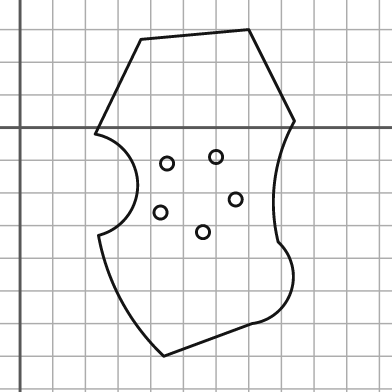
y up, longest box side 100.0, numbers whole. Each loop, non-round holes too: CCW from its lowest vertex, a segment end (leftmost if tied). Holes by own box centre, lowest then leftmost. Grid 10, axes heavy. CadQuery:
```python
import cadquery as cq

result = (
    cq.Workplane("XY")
    .moveTo(44.0, -70.0)
    .lineTo(71.0, -60.0)
    .threePointArc((83.0, -50.0), (79.0, -35.0))
    .threePointArc((78.0, -16.0), (84.0, 2.0))
    .lineTo(70.0, 30.0)
    .lineTo(37.0, 27.0)
    .lineTo(23.0, -2.0)
    .threePointArc((36.0, -17.0), (24.0, -33.0))
    .threePointArc((31.0, -53.0), (44.0, -70.0))
    .close()
    .moveTo(56.0, -32.0)
    .circle(2.0)
    .moveTo(43.0, -26.0)
    .circle(2.0)
    .moveTo(66.0, -22.0)
    .circle(2.0)
    .moveTo(45.0, -11.0)
    .circle(2.0)
    .moveTo(60.0, -9.0)
    .circle(2.0)
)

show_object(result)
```